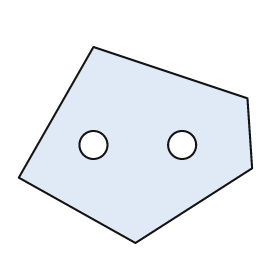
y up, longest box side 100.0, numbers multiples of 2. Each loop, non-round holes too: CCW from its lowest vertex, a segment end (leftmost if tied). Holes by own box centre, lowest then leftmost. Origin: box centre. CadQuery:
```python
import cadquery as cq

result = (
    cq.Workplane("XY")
    .moveTo(0.0, -42.0)
    .lineTo(50.0, -10.0)
    .lineTo(48.0, 20.0)
    .lineTo(-18.0, 42.0)
    .lineTo(-50.0, -14.0)
    .close()
    .moveTo(-18.0, 0.0)
    .circle(6.0)
    .moveTo(20.0, 0.0)
    .circle(6.0)
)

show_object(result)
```